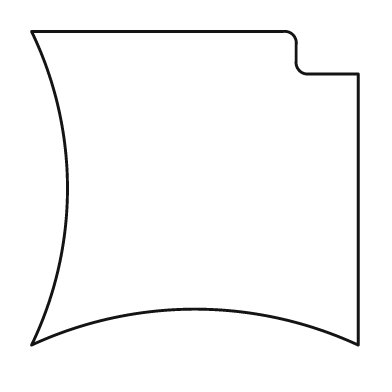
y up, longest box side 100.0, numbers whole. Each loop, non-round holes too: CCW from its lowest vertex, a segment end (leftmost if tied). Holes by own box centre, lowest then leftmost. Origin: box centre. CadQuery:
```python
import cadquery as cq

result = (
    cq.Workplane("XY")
    .moveTo(-50.0, -48.0)
    .threePointArc((0.0, -37.0), (50.0, -48.0))
    .lineTo(50.0, 35.0)
    .lineTo(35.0, 35.0)
    .threePointArc((32.0, 36.0), (31.0, 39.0))
    .lineTo(31.0, 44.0)
    .threePointArc((30.0, 47.0), (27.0, 48.0))
    .lineTo(-50.0, 48.0)
    .threePointArc((-39.0, 0.0), (-50.0, -48.0))
    .close()
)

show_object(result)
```